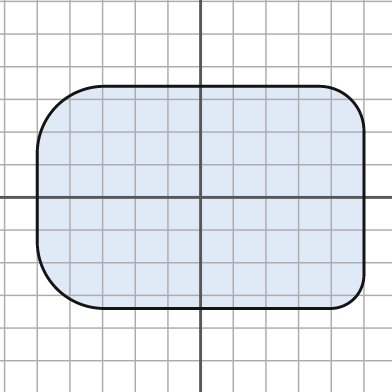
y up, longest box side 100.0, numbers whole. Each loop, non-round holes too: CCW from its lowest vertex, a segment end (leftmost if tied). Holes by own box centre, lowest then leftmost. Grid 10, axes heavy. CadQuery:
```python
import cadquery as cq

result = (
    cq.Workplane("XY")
    .moveTo(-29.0, -34.0)
    .lineTo(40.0, -34.0)
    .threePointArc((47.0, -31.0), (50.0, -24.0))
    .lineTo(50.0, 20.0)
    .threePointArc((46.0, 30.0), (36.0, 34.0))
    .lineTo(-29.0, 34.0)
    .threePointArc((-44.0, 28.0), (-50.0, 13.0))
    .lineTo(-50.0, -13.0)
    .threePointArc((-44.0, -28.0), (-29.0, -34.0))
    .close()
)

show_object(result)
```